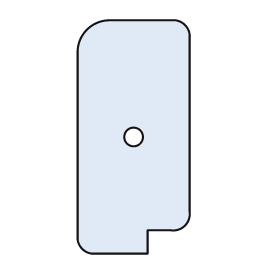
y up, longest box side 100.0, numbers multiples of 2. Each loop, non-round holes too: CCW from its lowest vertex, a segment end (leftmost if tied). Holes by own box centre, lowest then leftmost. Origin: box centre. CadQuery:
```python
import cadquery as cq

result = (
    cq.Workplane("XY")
    .moveTo(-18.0, -50.0)
    .lineTo(6.0, -50.0)
    .lineTo(6.0, -40.0)
    .lineTo(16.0, -40.0)
    .threePointArc((22.0, -38.0), (24.0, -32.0))
    .lineTo(24.0, 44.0)
    .threePointArc((22.0, 48.0), (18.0, 50.0))
    .lineTo(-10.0, 50.0)
    .threePointArc((-20.0, 46.0), (-24.0, 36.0))
    .lineTo(-24.0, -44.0)
    .threePointArc((-22.0, -48.0), (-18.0, -50.0))
    .close()
    .moveTo(0.0, 0.0)
    .circle(4.0)
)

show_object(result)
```